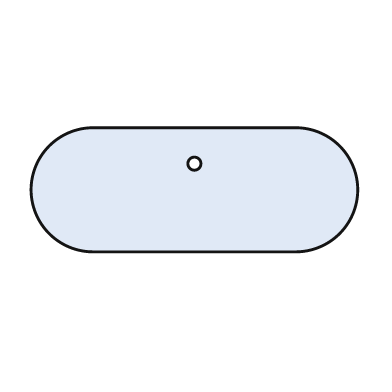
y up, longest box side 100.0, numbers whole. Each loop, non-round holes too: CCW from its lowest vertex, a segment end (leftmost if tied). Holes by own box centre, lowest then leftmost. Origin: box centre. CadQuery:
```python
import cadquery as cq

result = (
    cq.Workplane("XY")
    .moveTo(-31.0, -19.0)
    .lineTo(31.0, -19.0)
    .threePointArc((50.0, 0.0), (31.0, 19.0))
    .lineTo(-31.0, 19.0)
    .threePointArc((-50.0, 0.0), (-31.0, -19.0))
    .close()
    .moveTo(0.0, 8.0)
    .circle(2.0)
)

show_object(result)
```